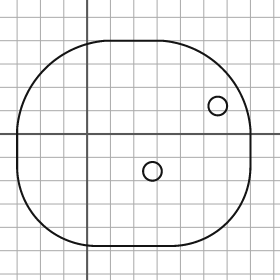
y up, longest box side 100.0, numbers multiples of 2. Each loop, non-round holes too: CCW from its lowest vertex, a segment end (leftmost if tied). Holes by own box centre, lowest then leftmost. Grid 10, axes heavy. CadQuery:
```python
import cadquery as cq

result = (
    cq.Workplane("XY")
    .moveTo(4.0, -48.0)
    .lineTo(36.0, -48.0)
    .threePointArc((60.0, -38.0), (70.0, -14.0))
    .lineTo(70.0, 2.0)
    .threePointArc((58.0, 28.0), (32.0, 40.0))
    .lineTo(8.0, 40.0)
    .threePointArc((-18.0, 28.0), (-30.0, 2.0))
    .lineTo(-30.0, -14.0)
    .threePointArc((-20.0, -38.0), (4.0, -48.0))
    .close()
    .moveTo(28.0, -16.0)
    .circle(4.0)
    .moveTo(56.0, 12.0)
    .circle(4.0)
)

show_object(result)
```